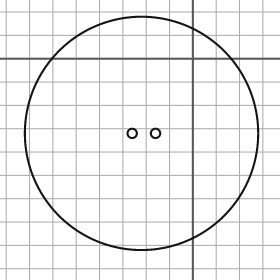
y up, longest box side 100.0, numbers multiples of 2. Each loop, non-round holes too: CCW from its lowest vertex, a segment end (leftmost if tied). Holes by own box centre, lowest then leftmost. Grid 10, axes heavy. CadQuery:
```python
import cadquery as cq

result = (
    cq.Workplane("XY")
    .moveTo(-22.0, -32.0)
    .circle(50.0)
    .moveTo(-26.0, -32.0)
    .circle(2.0)
    .moveTo(-16.0, -32.0)
    .circle(2.0)
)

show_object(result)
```